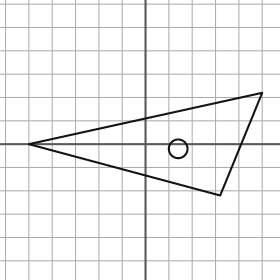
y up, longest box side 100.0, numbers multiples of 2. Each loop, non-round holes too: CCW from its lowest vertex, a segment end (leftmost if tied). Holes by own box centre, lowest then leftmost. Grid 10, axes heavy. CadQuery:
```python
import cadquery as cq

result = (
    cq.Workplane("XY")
    .moveTo(32.0, -22.0)
    .lineTo(50.0, 22.0)
    .lineTo(-50.0, 0.0)
    .close()
    .moveTo(14.0, -2.0)
    .circle(4.0)
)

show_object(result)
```